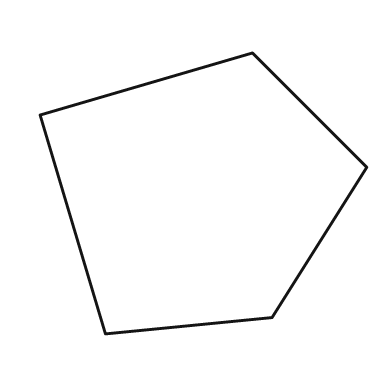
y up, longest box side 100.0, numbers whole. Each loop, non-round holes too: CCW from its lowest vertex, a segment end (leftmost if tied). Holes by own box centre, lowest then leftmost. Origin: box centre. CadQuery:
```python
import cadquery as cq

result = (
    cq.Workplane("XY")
    .moveTo(-30.0, -43.0)
    .lineTo(21.0, -38.0)
    .lineTo(50.0, 8.0)
    .lineTo(15.0, 43.0)
    .lineTo(-50.0, 24.0)
    .close()
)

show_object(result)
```